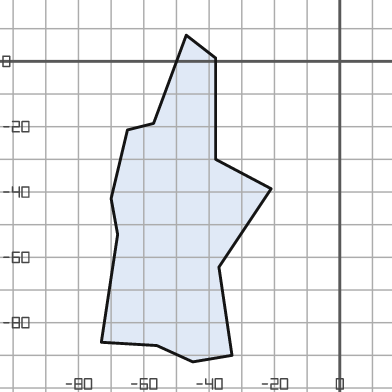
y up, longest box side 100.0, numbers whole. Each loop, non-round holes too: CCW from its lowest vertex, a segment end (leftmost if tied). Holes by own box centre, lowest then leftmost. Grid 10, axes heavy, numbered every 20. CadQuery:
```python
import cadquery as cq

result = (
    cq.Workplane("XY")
    .moveTo(-45.0, -92.0)
    .lineTo(-33.0, -90.0)
    .lineTo(-37.0, -63.0)
    .lineTo(-21.0, -39.0)
    .lineTo(-38.0, -30.0)
    .lineTo(-38.0, 1.0)
    .lineTo(-47.0, 8.0)
    .lineTo(-57.0, -19.0)
    .lineTo(-65.0, -21.0)
    .lineTo(-70.0, -42.0)
    .lineTo(-68.0, -53.0)
    .lineTo(-73.0, -86.0)
    .lineTo(-56.0, -87.0)
    .close()
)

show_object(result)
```